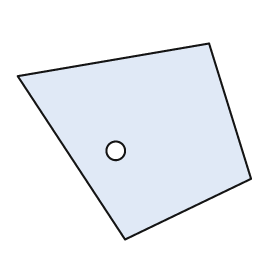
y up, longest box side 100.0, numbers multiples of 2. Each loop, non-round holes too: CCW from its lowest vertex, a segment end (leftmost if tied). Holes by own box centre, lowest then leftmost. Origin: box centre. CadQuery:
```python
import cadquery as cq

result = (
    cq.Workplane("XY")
    .moveTo(-4.0, -42.0)
    .lineTo(50.0, -16.0)
    .lineTo(32.0, 42.0)
    .lineTo(-50.0, 28.0)
    .close()
    .moveTo(-8.0, -4.0)
    .circle(4.0)
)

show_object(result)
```